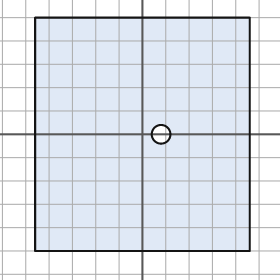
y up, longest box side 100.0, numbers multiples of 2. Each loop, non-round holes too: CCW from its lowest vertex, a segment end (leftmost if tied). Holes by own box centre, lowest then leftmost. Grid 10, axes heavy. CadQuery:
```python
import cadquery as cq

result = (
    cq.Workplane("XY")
    .moveTo(-46.0, -50.0)
    .lineTo(46.0, -50.0)
    .lineTo(46.0, 50.0)
    .lineTo(-46.0, 50.0)
    .close()
    .moveTo(8.0, 0.0)
    .circle(4.0)
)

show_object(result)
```